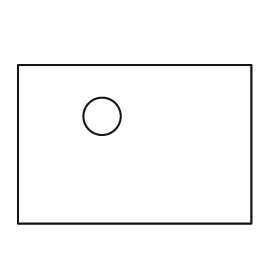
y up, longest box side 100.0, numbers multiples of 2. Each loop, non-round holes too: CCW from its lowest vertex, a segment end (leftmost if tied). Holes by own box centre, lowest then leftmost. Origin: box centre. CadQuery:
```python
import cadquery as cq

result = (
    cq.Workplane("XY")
    .moveTo(-50.0, -34.0)
    .lineTo(50.0, -34.0)
    .lineTo(50.0, 34.0)
    .lineTo(-50.0, 34.0)
    .close()
    .moveTo(-14.0, 12.0)
    .circle(8.0)
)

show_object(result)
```